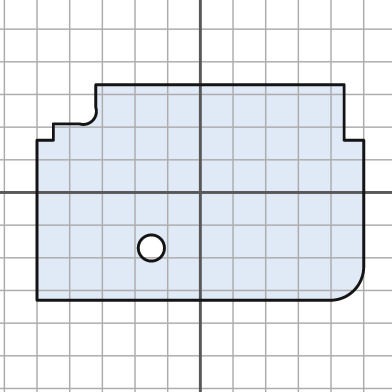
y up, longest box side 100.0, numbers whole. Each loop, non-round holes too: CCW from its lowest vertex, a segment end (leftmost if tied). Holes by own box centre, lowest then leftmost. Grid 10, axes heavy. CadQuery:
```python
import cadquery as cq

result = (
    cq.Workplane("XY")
    .moveTo(-50.0, -33.0)
    .lineTo(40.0, -33.0)
    .threePointArc((47.0, -30.0), (50.0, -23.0))
    .lineTo(50.0, 16.0)
    .lineTo(44.0, 16.0)
    .lineTo(44.0, 33.0)
    .lineTo(-32.0, 33.0)
    .lineTo(-32.0, 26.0)
    .threePointArc((-33.0, 22.0), (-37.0, 21.0))
    .lineTo(-45.0, 21.0)
    .lineTo(-45.0, 16.0)
    .lineTo(-50.0, 16.0)
    .close()
    .moveTo(-15.0, -17.0)
    .circle(4.0)
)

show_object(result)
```